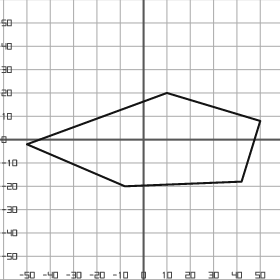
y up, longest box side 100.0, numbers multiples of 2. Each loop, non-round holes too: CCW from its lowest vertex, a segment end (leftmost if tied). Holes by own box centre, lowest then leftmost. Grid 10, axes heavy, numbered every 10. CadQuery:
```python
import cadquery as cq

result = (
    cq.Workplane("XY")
    .moveTo(-8.0, -20.0)
    .lineTo(42.0, -18.0)
    .lineTo(50.0, 8.0)
    .lineTo(10.0, 20.0)
    .lineTo(-50.0, -2.0)
    .close()
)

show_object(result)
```